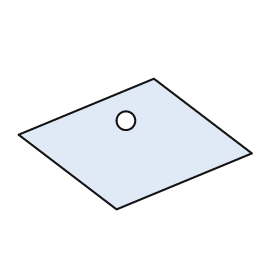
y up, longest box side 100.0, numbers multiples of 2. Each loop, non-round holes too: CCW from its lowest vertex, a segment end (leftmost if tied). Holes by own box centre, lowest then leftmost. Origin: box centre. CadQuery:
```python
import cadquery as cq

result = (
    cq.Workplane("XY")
    .moveTo(-8.0, -28.0)
    .lineTo(50.0, -4.0)
    .lineTo(8.0, 28.0)
    .lineTo(-50.0, 4.0)
    .close()
    .moveTo(-4.0, 10.0)
    .circle(4.0)
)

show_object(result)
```